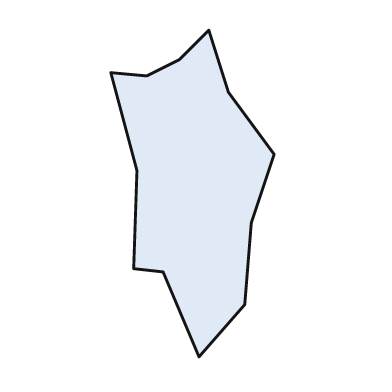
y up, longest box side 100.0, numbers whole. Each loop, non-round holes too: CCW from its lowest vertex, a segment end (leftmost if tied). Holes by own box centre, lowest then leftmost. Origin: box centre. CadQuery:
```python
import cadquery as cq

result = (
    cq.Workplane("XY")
    .moveTo(2.0, -50.0)
    .lineTo(16.0, -34.0)
    .lineTo(18.0, -9.0)
    .lineTo(25.0, 12.0)
    .lineTo(11.0, 31.0)
    .lineTo(5.0, 50.0)
    .lineTo(-4.0, 41.0)
    .lineTo(-14.0, 36.0)
    .lineTo(-25.0, 37.0)
    .lineTo(-17.0, 7.0)
    .lineTo(-18.0, -23.0)
    .lineTo(-9.0, -24.0)
    .close()
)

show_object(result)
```